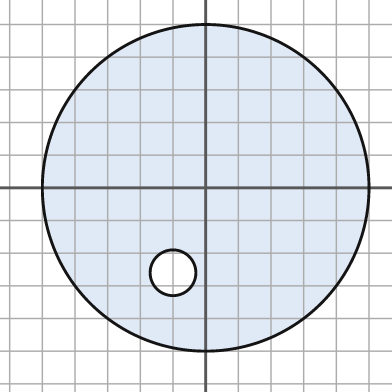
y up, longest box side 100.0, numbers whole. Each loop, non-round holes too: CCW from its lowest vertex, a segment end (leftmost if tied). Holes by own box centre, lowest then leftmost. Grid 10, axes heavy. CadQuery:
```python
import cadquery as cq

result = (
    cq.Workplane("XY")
    .moveTo(0.0, 0.0)
    .circle(50.0)
    .moveTo(-10.0, -26.0)
    .circle(7.0)
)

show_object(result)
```